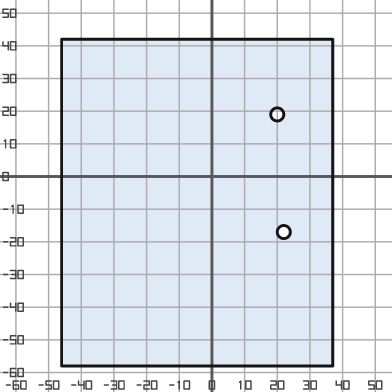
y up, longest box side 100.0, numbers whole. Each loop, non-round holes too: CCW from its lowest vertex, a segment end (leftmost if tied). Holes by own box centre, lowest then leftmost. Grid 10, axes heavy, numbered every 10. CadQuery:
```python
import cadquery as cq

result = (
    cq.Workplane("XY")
    .moveTo(-46.0, -58.0)
    .lineTo(37.0, -58.0)
    .lineTo(37.0, 42.0)
    .lineTo(-46.0, 42.0)
    .close()
    .moveTo(22.0, -17.0)
    .circle(2.0)
    .moveTo(20.0, 19.0)
    .circle(2.0)
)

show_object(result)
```